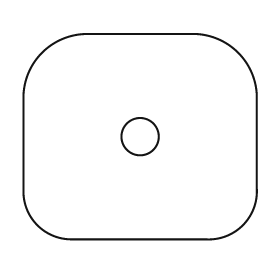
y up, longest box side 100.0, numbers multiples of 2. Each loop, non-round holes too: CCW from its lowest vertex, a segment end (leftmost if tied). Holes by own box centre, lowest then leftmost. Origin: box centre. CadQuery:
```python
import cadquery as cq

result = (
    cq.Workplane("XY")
    .moveTo(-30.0, -44.0)
    .lineTo(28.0, -44.0)
    .threePointArc((44.0, -38.0), (50.0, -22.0))
    .lineTo(50.0, 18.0)
    .threePointArc((42.0, 36.0), (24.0, 44.0))
    .lineTo(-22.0, 44.0)
    .threePointArc((-42.0, 36.0), (-50.0, 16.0))
    .lineTo(-50.0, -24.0)
    .threePointArc((-44.0, -38.0), (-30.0, -44.0))
    .close()
    .moveTo(0.0, 0.0)
    .circle(8.0)
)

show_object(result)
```